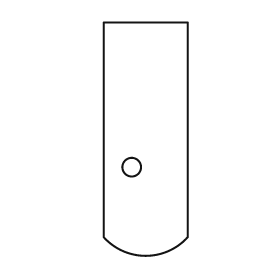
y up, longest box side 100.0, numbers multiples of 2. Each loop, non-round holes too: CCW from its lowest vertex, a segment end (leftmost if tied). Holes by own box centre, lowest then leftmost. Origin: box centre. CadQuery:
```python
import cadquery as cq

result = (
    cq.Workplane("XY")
    .moveTo(-18.0, -42.0)
    .threePointArc((0.0, -50.0), (18.0, -42.0))
    .lineTo(18.0, 50.0)
    .lineTo(-18.0, 50.0)
    .close()
    .moveTo(-6.0, -12.0)
    .circle(4.0)
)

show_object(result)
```